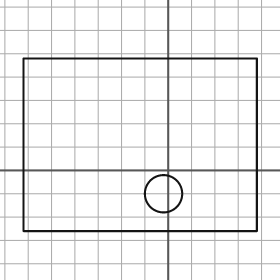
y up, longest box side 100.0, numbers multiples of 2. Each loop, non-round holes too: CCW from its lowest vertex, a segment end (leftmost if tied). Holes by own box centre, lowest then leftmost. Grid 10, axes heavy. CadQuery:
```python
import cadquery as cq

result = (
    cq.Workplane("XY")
    .moveTo(-62.0, -26.0)
    .lineTo(38.0, -26.0)
    .lineTo(38.0, 48.0)
    .lineTo(-62.0, 48.0)
    .close()
    .moveTo(-2.0, -10.0)
    .circle(8.0)
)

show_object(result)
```